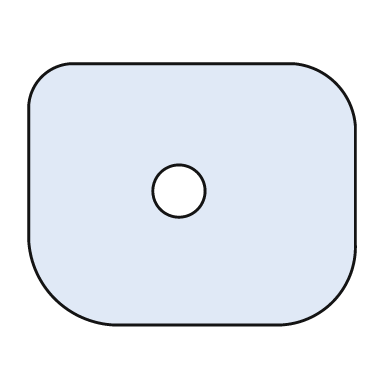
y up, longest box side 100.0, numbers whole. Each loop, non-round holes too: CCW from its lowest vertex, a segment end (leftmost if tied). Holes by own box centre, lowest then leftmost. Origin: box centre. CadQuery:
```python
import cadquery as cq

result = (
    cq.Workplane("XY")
    .moveTo(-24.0, -40.0)
    .lineTo(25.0, -40.0)
    .threePointArc((43.0, -33.0), (50.0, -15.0))
    .lineTo(50.0, 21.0)
    .threePointArc((44.0, 34.0), (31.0, 40.0))
    .lineTo(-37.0, 40.0)
    .threePointArc((-46.0, 36.0), (-50.0, 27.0))
    .lineTo(-50.0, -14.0)
    .threePointArc((-42.0, -32.0), (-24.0, -40.0))
    .close()
    .moveTo(-4.0, 1.0)
    .circle(8.0)
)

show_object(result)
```